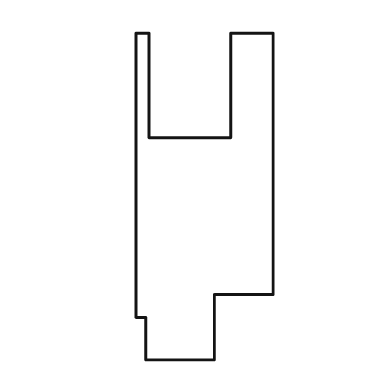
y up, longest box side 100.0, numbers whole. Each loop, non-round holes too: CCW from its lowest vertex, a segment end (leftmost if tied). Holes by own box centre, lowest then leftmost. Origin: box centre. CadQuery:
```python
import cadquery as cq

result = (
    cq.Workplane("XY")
    .moveTo(-18.0, -50.0)
    .lineTo(3.0, -50.0)
    .lineTo(3.0, -30.0)
    .lineTo(21.0, -30.0)
    .lineTo(21.0, 50.0)
    .lineTo(8.0, 50.0)
    .lineTo(8.0, 18.0)
    .lineTo(-17.0, 18.0)
    .lineTo(-17.0, 50.0)
    .lineTo(-21.0, 50.0)
    .lineTo(-21.0, -37.0)
    .lineTo(-18.0, -37.0)
    .close()
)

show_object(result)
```